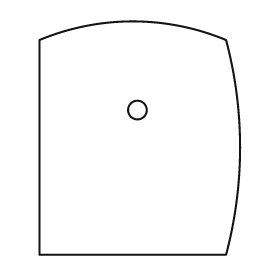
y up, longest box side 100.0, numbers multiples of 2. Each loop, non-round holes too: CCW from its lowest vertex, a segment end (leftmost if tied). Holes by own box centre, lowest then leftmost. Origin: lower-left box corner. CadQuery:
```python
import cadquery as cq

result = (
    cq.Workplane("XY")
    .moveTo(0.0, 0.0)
    .lineTo(80.0, 0.0)
    .threePointArc((86.0, 46.0), (80.0, 92.0))
    .threePointArc((40.0, 100.0), (0.0, 92.0))
    .close()
    .moveTo(42.0, 62.0)
    .circle(4.0)
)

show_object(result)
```